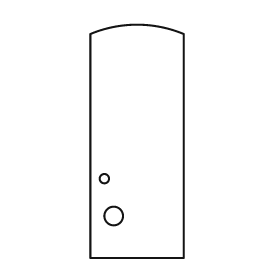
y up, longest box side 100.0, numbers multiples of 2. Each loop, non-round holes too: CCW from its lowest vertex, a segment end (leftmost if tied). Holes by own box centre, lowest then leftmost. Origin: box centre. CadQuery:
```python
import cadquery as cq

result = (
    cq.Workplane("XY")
    .moveTo(-20.0, -50.0)
    .lineTo(20.0, -50.0)
    .lineTo(20.0, 46.0)
    .threePointArc((0.0, 50.0), (-20.0, 46.0))
    .close()
    .moveTo(-10.0, -32.0)
    .circle(4.0)
    .moveTo(-14.0, -16.0)
    .circle(2.0)
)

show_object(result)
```